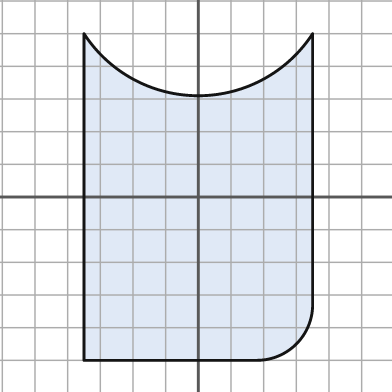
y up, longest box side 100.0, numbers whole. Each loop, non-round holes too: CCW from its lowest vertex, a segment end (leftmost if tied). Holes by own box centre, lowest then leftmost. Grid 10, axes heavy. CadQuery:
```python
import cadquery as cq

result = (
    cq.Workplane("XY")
    .moveTo(-35.0, -50.0)
    .lineTo(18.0, -50.0)
    .threePointArc((30.0, -45.0), (35.0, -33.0))
    .lineTo(35.0, 50.0)
    .threePointArc((0.0, 31.0), (-35.0, 50.0))
    .close()
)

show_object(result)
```